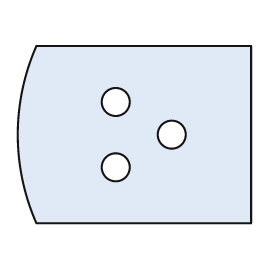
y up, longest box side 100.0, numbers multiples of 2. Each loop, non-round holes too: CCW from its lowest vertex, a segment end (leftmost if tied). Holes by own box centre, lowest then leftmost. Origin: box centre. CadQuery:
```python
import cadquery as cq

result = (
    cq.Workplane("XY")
    .moveTo(-42.0, -38.0)
    .lineTo(50.0, -38.0)
    .lineTo(50.0, 38.0)
    .lineTo(-42.0, 38.0)
    .threePointArc((-50.0, 0.0), (-42.0, -38.0))
    .close()
    .moveTo(-8.0, -14.0)
    .circle(6.0)
    .moveTo(16.0, 0.0)
    .circle(6.0)
    .moveTo(-8.0, 14.0)
    .circle(6.0)
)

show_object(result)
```